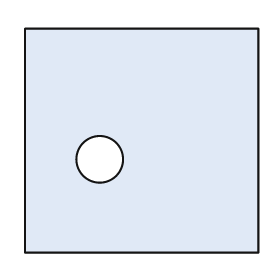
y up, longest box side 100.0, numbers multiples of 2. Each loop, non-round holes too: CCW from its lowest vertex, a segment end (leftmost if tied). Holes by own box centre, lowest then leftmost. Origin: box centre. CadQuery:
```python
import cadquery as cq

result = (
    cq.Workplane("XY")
    .moveTo(-50.0, -48.0)
    .lineTo(50.0, -48.0)
    .lineTo(50.0, 48.0)
    .lineTo(-50.0, 48.0)
    .close()
    .moveTo(-18.0, -8.0)
    .circle(10.0)
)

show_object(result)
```